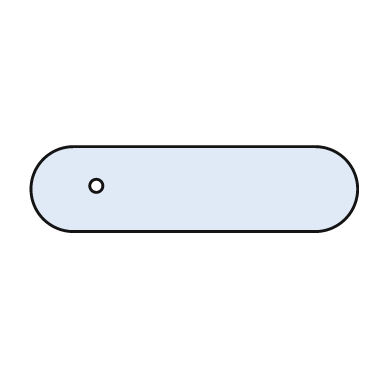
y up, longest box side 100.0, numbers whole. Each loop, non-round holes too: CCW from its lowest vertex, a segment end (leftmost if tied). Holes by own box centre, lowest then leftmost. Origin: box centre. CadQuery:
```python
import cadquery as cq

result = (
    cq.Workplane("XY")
    .moveTo(-37.0, -13.0)
    .lineTo(37.0, -13.0)
    .threePointArc((50.0, 0.0), (37.0, 13.0))
    .lineTo(-37.0, 13.0)
    .threePointArc((-50.0, 0.0), (-37.0, -13.0))
    .close()
    .moveTo(-30.0, 1.0)
    .circle(2.0)
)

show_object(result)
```